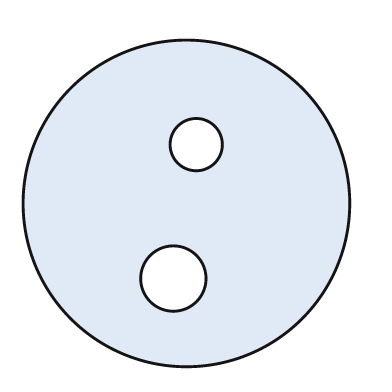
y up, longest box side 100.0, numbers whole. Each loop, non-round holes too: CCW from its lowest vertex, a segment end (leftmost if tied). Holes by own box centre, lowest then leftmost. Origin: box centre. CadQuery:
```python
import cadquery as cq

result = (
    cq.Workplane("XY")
    .moveTo(0.0, 0.0)
    .circle(50.0)
    .moveTo(-4.0, -23.0)
    .circle(10.0)
    .moveTo(3.0, 18.0)
    .circle(8.0)
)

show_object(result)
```